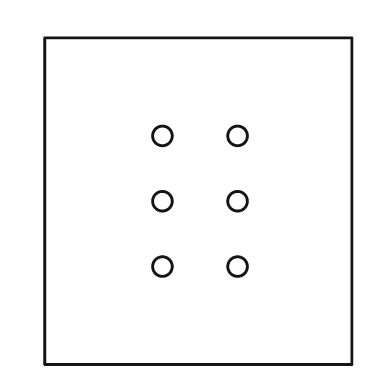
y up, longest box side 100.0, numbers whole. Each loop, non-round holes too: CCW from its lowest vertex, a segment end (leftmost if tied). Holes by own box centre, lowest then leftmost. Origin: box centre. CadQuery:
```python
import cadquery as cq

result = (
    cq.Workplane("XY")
    .moveTo(-47.0, -50.0)
    .lineTo(47.0, -50.0)
    .lineTo(47.0, 50.0)
    .lineTo(-47.0, 50.0)
    .close()
    .moveTo(-11.0, -20.0)
    .circle(3.0)
    .moveTo(12.0, -20.0)
    .circle(3.0)
    .moveTo(-11.0, 0.0)
    .circle(3.0)
    .moveTo(12.0, 0.0)
    .circle(3.0)
    .moveTo(-11.0, 20.0)
    .circle(3.0)
    .moveTo(12.0, 20.0)
    .circle(3.0)
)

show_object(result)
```